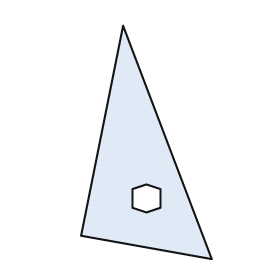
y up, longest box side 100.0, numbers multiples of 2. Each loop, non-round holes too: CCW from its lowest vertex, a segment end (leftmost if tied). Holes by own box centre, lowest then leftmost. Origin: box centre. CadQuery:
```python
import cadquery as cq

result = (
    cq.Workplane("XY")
    .moveTo(28.0, -50.0)
    .lineTo(-10.0, 50.0)
    .lineTo(-28.0, -40.0)
    .close()
    .moveTo(0.0, -30.0)
    .lineTo(6.0, -28.0)
    .lineTo(6.0, -20.0)
    .lineTo(0.0, -18.0)
    .lineTo(-6.0, -20.0)
    .lineTo(-6.0, -28.0)
    .close()
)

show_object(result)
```